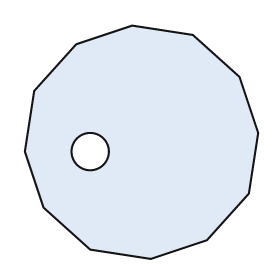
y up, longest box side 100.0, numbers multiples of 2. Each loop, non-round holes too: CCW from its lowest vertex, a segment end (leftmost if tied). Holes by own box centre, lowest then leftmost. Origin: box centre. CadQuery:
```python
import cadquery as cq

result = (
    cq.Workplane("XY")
    .moveTo(4.0, -50.0)
    .lineTo(28.0, -42.0)
    .lineTo(46.0, -22.0)
    .lineTo(50.0, 4.0)
    .lineTo(42.0, 28.0)
    .lineTo(22.0, 46.0)
    .lineTo(-4.0, 50.0)
    .lineTo(-28.0, 42.0)
    .lineTo(-46.0, 22.0)
    .lineTo(-50.0, -4.0)
    .lineTo(-42.0, -28.0)
    .lineTo(-22.0, -46.0)
    .close()
    .moveTo(-22.0, -4.0)
    .circle(8.0)
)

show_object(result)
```